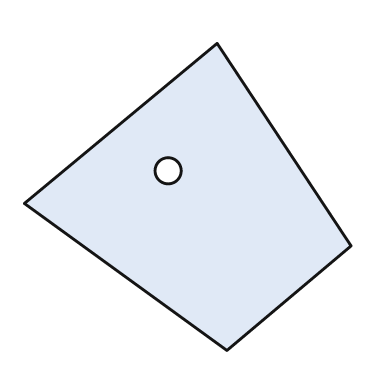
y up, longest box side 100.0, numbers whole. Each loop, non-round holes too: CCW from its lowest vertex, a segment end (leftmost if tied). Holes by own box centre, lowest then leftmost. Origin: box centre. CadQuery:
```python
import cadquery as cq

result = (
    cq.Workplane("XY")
    .moveTo(12.0, -47.0)
    .lineTo(50.0, -15.0)
    .lineTo(9.0, 47.0)
    .lineTo(-50.0, -2.0)
    .close()
    .moveTo(-6.0, 8.0)
    .circle(4.0)
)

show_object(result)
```